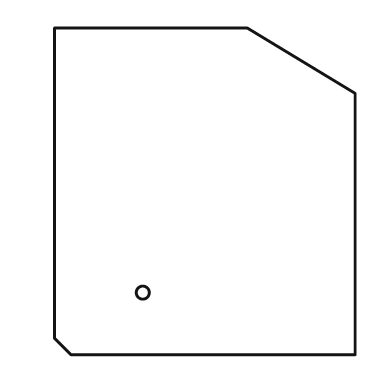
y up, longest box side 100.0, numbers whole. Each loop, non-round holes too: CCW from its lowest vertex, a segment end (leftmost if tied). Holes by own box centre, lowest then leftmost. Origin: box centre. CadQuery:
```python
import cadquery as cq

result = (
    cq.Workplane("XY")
    .moveTo(-41.0, -50.0)
    .lineTo(46.0, -50.0)
    .lineTo(46.0, 30.0)
    .lineTo(13.0, 50.0)
    .lineTo(-46.0, 50.0)
    .lineTo(-46.0, -45.0)
    .close()
    .moveTo(-19.0, -31.0)
    .circle(2.0)
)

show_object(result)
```